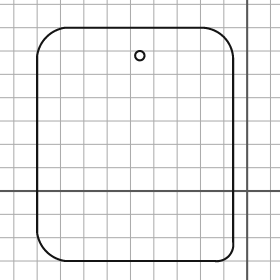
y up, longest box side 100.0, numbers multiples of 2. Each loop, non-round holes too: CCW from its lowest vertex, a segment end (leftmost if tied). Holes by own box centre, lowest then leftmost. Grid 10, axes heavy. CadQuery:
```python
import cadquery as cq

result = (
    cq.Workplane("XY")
    .moveTo(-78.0, -30.0)
    .lineTo(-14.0, -30.0)
    .threePointArc((-8.0, -28.0), (-6.0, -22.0))
    .lineTo(-6.0, 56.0)
    .threePointArc((-10.0, 66.0), (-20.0, 70.0))
    .lineTo(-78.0, 70.0)
    .threePointArc((-86.0, 66.0), (-90.0, 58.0))
    .lineTo(-90.0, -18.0)
    .threePointArc((-86.0, -26.0), (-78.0, -30.0))
    .close()
    .moveTo(-46.0, 58.0)
    .circle(2.0)
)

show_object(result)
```